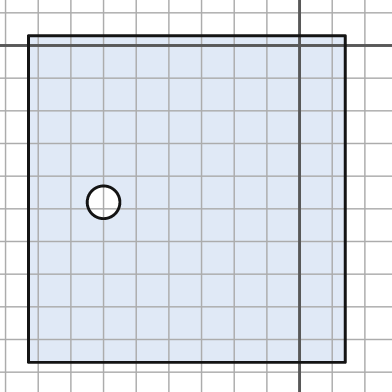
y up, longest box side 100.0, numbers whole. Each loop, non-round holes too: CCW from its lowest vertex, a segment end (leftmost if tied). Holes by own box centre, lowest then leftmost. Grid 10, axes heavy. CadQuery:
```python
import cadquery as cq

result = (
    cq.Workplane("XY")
    .moveTo(-83.0, -97.0)
    .lineTo(14.0, -97.0)
    .lineTo(14.0, 3.0)
    .lineTo(-83.0, 3.0)
    .close()
    .moveTo(-60.0, -48.0)
    .circle(5.0)
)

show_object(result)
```